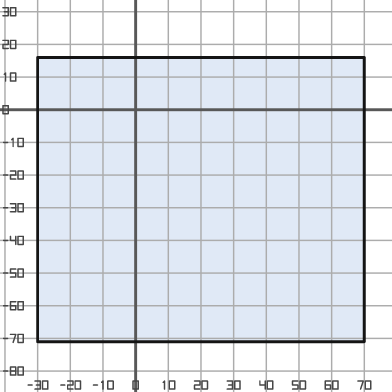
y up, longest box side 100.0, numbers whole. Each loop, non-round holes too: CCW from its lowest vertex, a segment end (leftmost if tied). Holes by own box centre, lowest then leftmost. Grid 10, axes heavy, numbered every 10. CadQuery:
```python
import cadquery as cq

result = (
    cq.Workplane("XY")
    .moveTo(-30.0, -71.0)
    .lineTo(70.0, -71.0)
    .lineTo(70.0, 16.0)
    .lineTo(-30.0, 16.0)
    .close()
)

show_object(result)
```